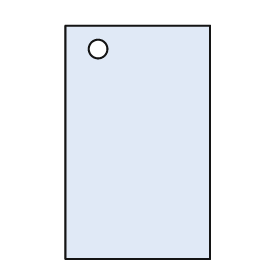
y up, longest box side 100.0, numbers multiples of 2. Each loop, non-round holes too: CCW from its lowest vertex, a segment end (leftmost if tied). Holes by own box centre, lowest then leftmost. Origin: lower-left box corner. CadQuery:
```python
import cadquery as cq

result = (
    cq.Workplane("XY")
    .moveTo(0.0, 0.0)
    .lineTo(62.0, 0.0)
    .lineTo(62.0, 100.0)
    .lineTo(0.0, 100.0)
    .close()
    .moveTo(14.0, 90.0)
    .circle(4.0)
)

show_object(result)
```